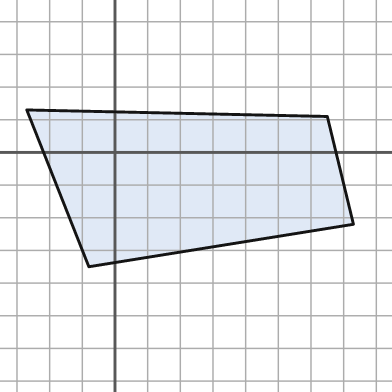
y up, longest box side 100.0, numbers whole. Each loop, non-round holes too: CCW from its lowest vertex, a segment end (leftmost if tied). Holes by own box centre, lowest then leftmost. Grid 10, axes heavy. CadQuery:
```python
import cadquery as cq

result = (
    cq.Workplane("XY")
    .moveTo(-8.0, -35.0)
    .lineTo(73.0, -22.0)
    .lineTo(65.0, 11.0)
    .lineTo(-27.0, 13.0)
    .close()
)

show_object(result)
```